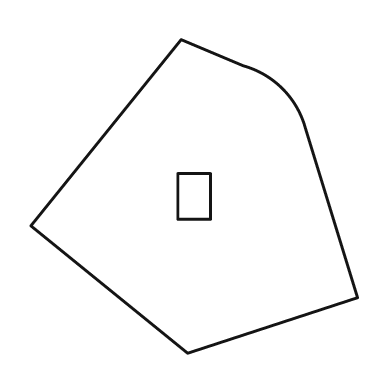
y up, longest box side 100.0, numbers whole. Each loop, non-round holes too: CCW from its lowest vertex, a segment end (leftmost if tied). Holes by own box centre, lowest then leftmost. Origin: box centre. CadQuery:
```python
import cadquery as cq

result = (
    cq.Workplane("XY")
    .moveTo(-2.0, -48.0)
    .lineTo(50.0, -31.0)
    .lineTo(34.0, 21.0)
    .threePointArc((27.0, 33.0), (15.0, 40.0))
    .lineTo(-4.0, 48.0)
    .lineTo(-50.0, -9.0)
    .close()
    .moveTo(-5.0, -7.0)
    .lineTo(5.0, -7.0)
    .lineTo(5.0, 7.0)
    .lineTo(-5.0, 7.0)
    .close()
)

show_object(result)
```